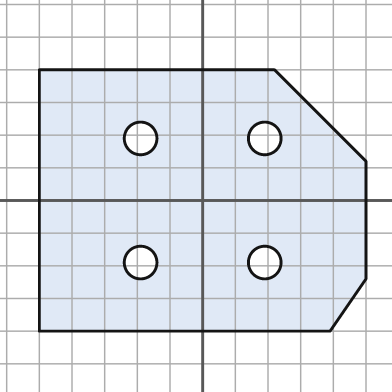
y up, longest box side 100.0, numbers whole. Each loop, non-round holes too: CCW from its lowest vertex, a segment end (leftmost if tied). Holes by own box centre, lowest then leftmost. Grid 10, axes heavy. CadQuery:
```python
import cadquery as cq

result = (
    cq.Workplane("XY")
    .moveTo(-50.0, -40.0)
    .lineTo(39.0, -40.0)
    .lineTo(50.0, -24.0)
    .lineTo(50.0, 12.0)
    .lineTo(22.0, 40.0)
    .lineTo(-50.0, 40.0)
    .close()
    .moveTo(-19.0, -19.0)
    .circle(5.0)
    .moveTo(19.0, -19.0)
    .circle(5.0)
    .moveTo(-19.0, 19.0)
    .circle(5.0)
    .moveTo(19.0, 19.0)
    .circle(5.0)
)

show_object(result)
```